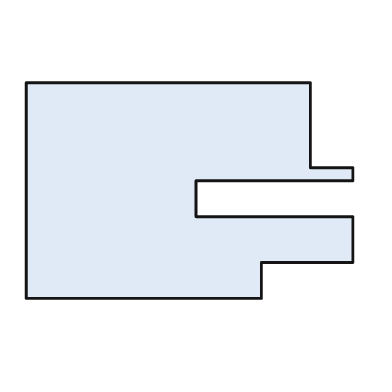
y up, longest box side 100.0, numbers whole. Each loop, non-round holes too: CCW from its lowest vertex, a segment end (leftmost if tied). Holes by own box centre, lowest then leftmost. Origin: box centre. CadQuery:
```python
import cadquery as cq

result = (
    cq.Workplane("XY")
    .moveTo(-50.0, -33.0)
    .lineTo(22.0, -33.0)
    .lineTo(22.0, -22.0)
    .lineTo(50.0, -22.0)
    .lineTo(50.0, -8.0)
    .lineTo(2.0, -8.0)
    .lineTo(2.0, 3.0)
    .lineTo(50.0, 3.0)
    .lineTo(50.0, 7.0)
    .lineTo(37.0, 7.0)
    .lineTo(37.0, 33.0)
    .lineTo(-50.0, 33.0)
    .close()
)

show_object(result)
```